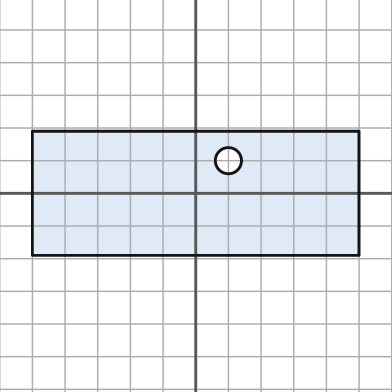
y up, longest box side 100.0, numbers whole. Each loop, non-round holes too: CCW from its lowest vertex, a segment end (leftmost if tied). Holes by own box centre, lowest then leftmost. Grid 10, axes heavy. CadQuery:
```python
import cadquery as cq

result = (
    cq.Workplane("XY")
    .moveTo(-50.0, -19.0)
    .lineTo(50.0, -19.0)
    .lineTo(50.0, 19.0)
    .lineTo(-50.0, 19.0)
    .close()
    .moveTo(10.0, 10.0)
    .circle(4.0)
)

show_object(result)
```